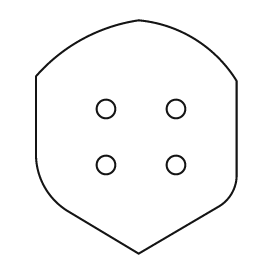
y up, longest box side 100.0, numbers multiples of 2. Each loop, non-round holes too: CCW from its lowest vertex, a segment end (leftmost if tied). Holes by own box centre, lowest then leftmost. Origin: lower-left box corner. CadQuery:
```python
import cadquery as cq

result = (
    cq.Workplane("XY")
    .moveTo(44.0, 0.0)
    .lineTo(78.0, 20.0)
    .threePointArc((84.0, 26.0), (86.0, 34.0))
    .lineTo(86.0, 74.0)
    .threePointArc((68.0, 92.0), (44.0, 100.0))
    .threePointArc((20.0, 92.0), (0.0, 76.0))
    .lineTo(0.0, 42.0)
    .threePointArc((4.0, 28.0), (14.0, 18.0))
    .close()
    .moveTo(30.0, 38.0)
    .circle(4.0)
    .moveTo(60.0, 38.0)
    .circle(4.0)
    .moveTo(30.0, 62.0)
    .circle(4.0)
    .moveTo(60.0, 62.0)
    .circle(4.0)
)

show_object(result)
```